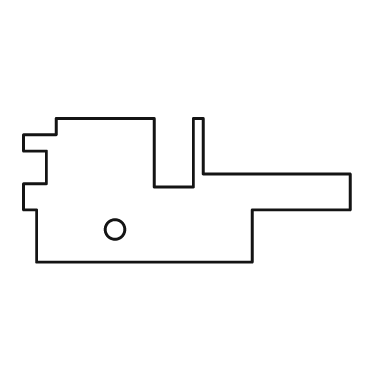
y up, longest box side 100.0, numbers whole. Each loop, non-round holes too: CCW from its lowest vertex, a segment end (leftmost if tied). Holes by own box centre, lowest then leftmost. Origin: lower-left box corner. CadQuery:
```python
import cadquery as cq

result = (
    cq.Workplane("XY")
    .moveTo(4.0, 0.0)
    .lineTo(70.0, 0.0)
    .lineTo(70.0, 16.0)
    .lineTo(100.0, 16.0)
    .lineTo(100.0, 27.0)
    .lineTo(55.0, 27.0)
    .lineTo(55.0, 44.0)
    .lineTo(52.0, 44.0)
    .lineTo(52.0, 23.0)
    .lineTo(40.0, 23.0)
    .lineTo(40.0, 44.0)
    .lineTo(10.0, 44.0)
    .lineTo(10.0, 39.0)
    .lineTo(0.0, 39.0)
    .lineTo(0.0, 34.0)
    .lineTo(7.0, 34.0)
    .lineTo(7.0, 24.0)
    .lineTo(0.0, 24.0)
    .lineTo(0.0, 16.0)
    .lineTo(4.0, 16.0)
    .close()
    .moveTo(28.0, 10.0)
    .circle(3.0)
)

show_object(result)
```